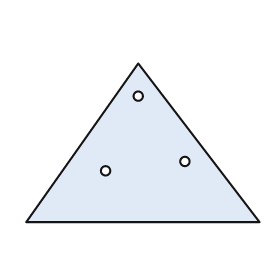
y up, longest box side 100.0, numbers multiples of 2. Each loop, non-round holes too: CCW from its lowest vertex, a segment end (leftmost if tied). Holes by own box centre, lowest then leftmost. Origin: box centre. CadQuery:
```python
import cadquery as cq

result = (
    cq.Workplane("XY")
    .moveTo(-50.0, -34.0)
    .lineTo(50.0, -34.0)
    .lineTo(-2.0, 34.0)
    .close()
    .moveTo(-16.0, -12.0)
    .circle(2.0)
    .moveTo(18.0, -8.0)
    .circle(2.0)
    .moveTo(-2.0, 20.0)
    .circle(2.0)
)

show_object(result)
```